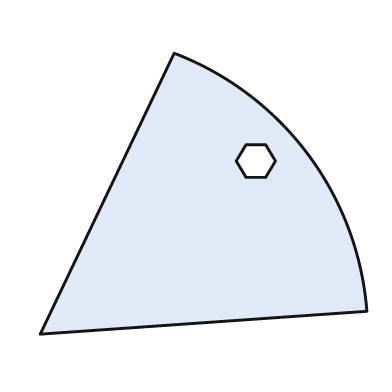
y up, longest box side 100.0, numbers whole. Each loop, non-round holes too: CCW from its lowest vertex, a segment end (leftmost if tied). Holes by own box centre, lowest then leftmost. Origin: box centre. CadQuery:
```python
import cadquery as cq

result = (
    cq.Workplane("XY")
    .moveTo(-50.0, -43.0)
    .lineTo(50.0, -36.0)
    .threePointArc((32.0, 12.0), (-9.0, 43.0))
    .close()
    .moveTo(13.0, 5.0)
    .lineTo(19.0, 5.0)
    .lineTo(22.0, 10.0)
    .lineTo(19.0, 15.0)
    .lineTo(13.0, 15.0)
    .lineTo(10.0, 10.0)
    .close()
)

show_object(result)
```